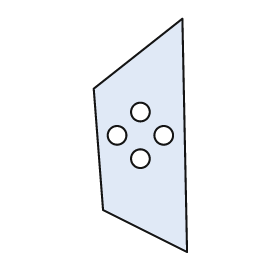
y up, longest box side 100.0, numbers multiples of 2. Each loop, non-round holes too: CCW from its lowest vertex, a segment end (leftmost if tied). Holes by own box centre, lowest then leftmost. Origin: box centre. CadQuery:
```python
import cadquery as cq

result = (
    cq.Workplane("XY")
    .moveTo(20.0, -50.0)
    .lineTo(18.0, 50.0)
    .lineTo(-20.0, 20.0)
    .lineTo(-16.0, -32.0)
    .close()
    .moveTo(0.0, -10.0)
    .circle(4.0)
    .moveTo(-10.0, 0.0)
    .circle(4.0)
    .moveTo(10.0, 0.0)
    .circle(4.0)
    .moveTo(0.0, 10.0)
    .circle(4.0)
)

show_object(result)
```